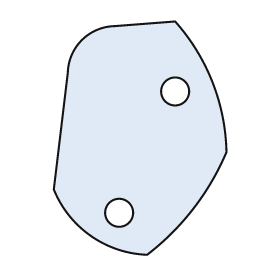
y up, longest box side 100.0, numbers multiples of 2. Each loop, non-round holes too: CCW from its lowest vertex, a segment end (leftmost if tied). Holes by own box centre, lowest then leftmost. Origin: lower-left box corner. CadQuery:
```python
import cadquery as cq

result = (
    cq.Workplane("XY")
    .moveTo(40.0, 0.0)
    .threePointArc((60.0, 20.0), (74.0, 44.0))
    .threePointArc((68.0, 74.0), (52.0, 100.0))
    .lineTo(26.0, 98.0)
    .threePointArc((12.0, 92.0), (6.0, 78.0))
    .lineTo(0.0, 28.0)
    .threePointArc((16.0, 8.0), (40.0, 0.0))
    .close()
    .moveTo(28.0, 18.0)
    .circle(6.0)
    .moveTo(52.0, 70.0)
    .circle(6.0)
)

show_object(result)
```